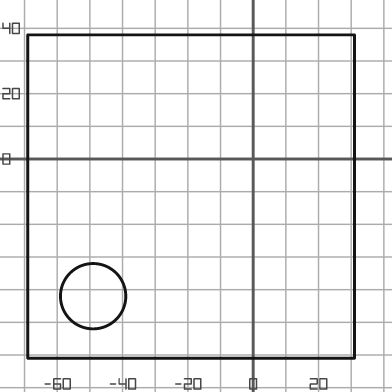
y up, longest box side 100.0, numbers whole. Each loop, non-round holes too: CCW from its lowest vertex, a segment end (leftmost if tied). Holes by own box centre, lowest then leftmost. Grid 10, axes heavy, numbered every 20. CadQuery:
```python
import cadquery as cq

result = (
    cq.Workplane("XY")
    .moveTo(-69.0, -61.0)
    .lineTo(31.0, -61.0)
    .lineTo(31.0, 38.0)
    .lineTo(-69.0, 38.0)
    .close()
    .moveTo(-49.0, -42.0)
    .circle(10.0)
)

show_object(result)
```